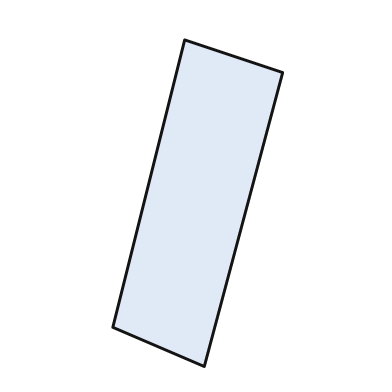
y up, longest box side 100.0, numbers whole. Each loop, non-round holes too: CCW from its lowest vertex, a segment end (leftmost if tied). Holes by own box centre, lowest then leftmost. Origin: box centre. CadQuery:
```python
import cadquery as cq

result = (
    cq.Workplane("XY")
    .moveTo(2.0, -50.0)
    .lineTo(26.0, 40.0)
    .lineTo(-4.0, 50.0)
    .lineTo(-26.0, -38.0)
    .close()
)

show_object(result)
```